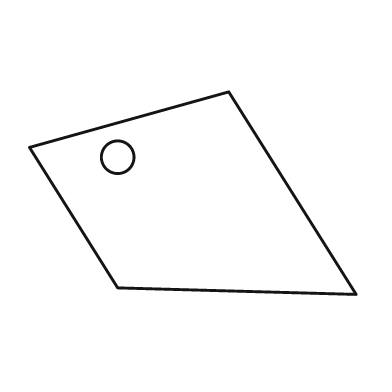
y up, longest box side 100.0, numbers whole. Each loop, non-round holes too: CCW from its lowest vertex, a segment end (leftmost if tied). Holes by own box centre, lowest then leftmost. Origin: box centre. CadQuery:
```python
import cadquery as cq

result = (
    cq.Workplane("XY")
    .moveTo(50.0, -31.0)
    .lineTo(11.0, 31.0)
    .lineTo(-50.0, 14.0)
    .lineTo(-23.0, -29.0)
    .close()
    .moveTo(-23.0, 11.0)
    .circle(5.0)
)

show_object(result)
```